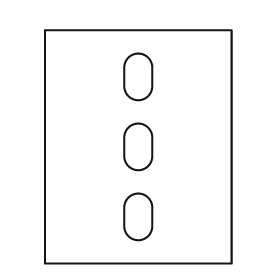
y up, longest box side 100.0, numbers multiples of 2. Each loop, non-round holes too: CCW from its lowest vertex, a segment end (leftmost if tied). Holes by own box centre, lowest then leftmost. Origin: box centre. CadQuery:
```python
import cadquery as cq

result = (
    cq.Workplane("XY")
    .moveTo(-40.0, -50.0)
    .lineTo(40.0, -50.0)
    .lineTo(40.0, 50.0)
    .lineTo(-40.0, 50.0)
    .close()
    .moveTo(-6.0, -34.0)
    .threePointArc((0.0, -40.0), (6.0, -34.0))
    .lineTo(6.0, -26.0)
    .threePointArc((0.0, -20.0), (-6.0, -26.0))
    .close()
    .moveTo(-6.0, -4.0)
    .threePointArc((0.0, -10.0), (6.0, -4.0))
    .lineTo(6.0, 4.0)
    .threePointArc((0.0, 10.0), (-6.0, 4.0))
    .close()
    .moveTo(-6.0, 26.0)
    .threePointArc((0.0, 20.0), (6.0, 26.0))
    .lineTo(6.0, 34.0)
    .threePointArc((0.0, 40.0), (-6.0, 34.0))
    .close()
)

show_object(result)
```